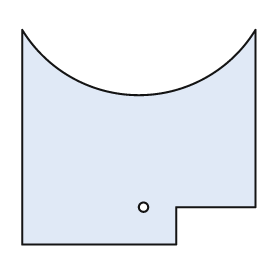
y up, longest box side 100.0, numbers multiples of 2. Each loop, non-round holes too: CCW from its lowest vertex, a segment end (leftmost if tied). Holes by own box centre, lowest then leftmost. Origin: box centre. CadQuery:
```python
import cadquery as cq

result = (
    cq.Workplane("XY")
    .moveTo(-50.0, -46.0)
    .lineTo(16.0, -46.0)
    .lineTo(16.0, -30.0)
    .lineTo(50.0, -30.0)
    .lineTo(50.0, 46.0)
    .threePointArc((0.0, 18.0), (-50.0, 46.0))
    .close()
    .moveTo(2.0, -30.0)
    .circle(2.0)
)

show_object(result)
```